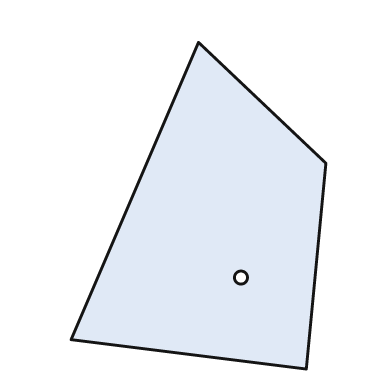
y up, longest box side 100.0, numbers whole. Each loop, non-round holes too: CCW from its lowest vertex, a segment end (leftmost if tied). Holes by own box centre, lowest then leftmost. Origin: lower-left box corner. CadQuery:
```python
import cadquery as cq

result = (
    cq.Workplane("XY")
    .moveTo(72.0, 0.0)
    .lineTo(78.0, 63.0)
    .lineTo(39.0, 100.0)
    .lineTo(0.0, 9.0)
    .close()
    .moveTo(52.0, 28.0)
    .circle(2.0)
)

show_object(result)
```